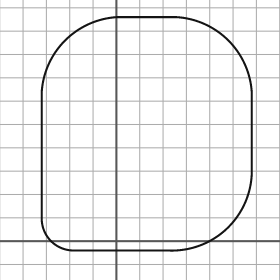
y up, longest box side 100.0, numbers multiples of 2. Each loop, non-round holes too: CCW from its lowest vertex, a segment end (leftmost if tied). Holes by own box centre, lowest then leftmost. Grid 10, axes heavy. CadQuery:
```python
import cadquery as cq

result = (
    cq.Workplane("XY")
    .moveTo(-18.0, -4.0)
    .lineTo(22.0, -4.0)
    .threePointArc((48.0, 6.0), (58.0, 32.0))
    .lineTo(58.0, 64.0)
    .threePointArc((48.0, 86.0), (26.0, 96.0))
    .lineTo(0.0, 96.0)
    .threePointArc((-22.0, 86.0), (-32.0, 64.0))
    .lineTo(-32.0, 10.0)
    .threePointArc((-28.0, 0.0), (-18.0, -4.0))
    .close()
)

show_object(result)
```